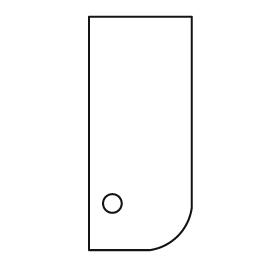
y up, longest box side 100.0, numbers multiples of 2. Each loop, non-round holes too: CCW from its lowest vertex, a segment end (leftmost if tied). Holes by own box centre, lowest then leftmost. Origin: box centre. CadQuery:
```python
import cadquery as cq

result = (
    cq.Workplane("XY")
    .moveTo(-22.0, -50.0)
    .lineTo(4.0, -50.0)
    .threePointArc((16.0, -44.0), (22.0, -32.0))
    .lineTo(22.0, 50.0)
    .lineTo(-22.0, 50.0)
    .close()
    .moveTo(-12.0, -30.0)
    .circle(4.0)
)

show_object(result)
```